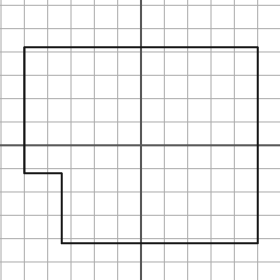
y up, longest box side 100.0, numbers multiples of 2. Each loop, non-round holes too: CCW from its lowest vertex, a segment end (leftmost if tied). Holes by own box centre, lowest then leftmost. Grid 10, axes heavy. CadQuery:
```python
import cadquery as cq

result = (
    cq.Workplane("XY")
    .moveTo(-34.0, -42.0)
    .lineTo(50.0, -42.0)
    .lineTo(50.0, 42.0)
    .lineTo(-50.0, 42.0)
    .lineTo(-50.0, -12.0)
    .lineTo(-34.0, -12.0)
    .close()
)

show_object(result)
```